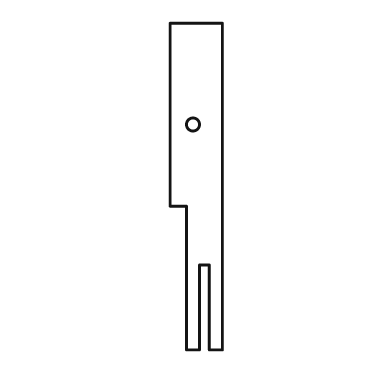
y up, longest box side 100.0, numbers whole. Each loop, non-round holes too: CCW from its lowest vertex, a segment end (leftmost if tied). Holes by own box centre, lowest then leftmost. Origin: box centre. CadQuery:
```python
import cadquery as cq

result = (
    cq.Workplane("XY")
    .moveTo(-3.0, -50.0)
    .lineTo(1.0, -50.0)
    .lineTo(1.0, -24.0)
    .lineTo(4.0, -24.0)
    .lineTo(4.0, -50.0)
    .lineTo(8.0, -50.0)
    .lineTo(8.0, 50.0)
    .lineTo(-8.0, 50.0)
    .lineTo(-8.0, -6.0)
    .lineTo(-3.0, -6.0)
    .close()
    .moveTo(-1.0, 19.0)
    .circle(2.0)
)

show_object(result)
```